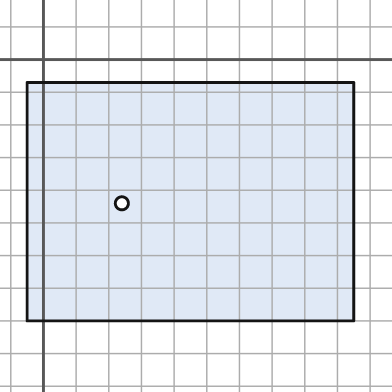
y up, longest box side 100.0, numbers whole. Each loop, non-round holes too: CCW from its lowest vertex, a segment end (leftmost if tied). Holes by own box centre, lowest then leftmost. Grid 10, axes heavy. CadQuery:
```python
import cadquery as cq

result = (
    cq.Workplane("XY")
    .moveTo(-5.0, -80.0)
    .lineTo(95.0, -80.0)
    .lineTo(95.0, -7.0)
    .lineTo(-5.0, -7.0)
    .close()
    .moveTo(24.0, -44.0)
    .circle(2.0)
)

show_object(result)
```